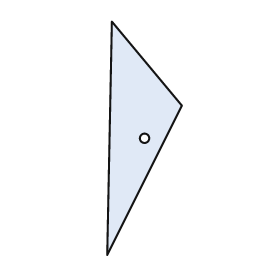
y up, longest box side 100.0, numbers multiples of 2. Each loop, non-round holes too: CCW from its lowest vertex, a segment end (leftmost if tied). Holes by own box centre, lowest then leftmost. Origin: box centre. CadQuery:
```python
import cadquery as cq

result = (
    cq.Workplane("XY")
    .moveTo(-16.0, -50.0)
    .lineTo(16.0, 14.0)
    .lineTo(-14.0, 50.0)
    .close()
    .moveTo(0.0, 0.0)
    .circle(2.0)
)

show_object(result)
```